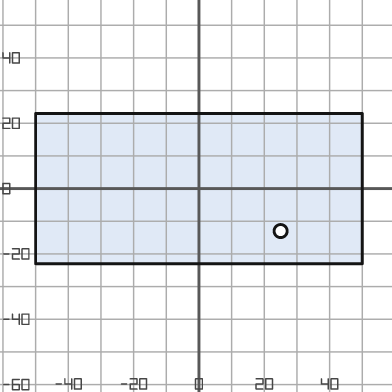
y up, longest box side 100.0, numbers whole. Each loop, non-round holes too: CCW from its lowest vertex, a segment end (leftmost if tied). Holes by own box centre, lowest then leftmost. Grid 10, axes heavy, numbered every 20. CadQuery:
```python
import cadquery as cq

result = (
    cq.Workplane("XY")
    .moveTo(-50.0, -23.0)
    .lineTo(50.0, -23.0)
    .lineTo(50.0, 23.0)
    .lineTo(-50.0, 23.0)
    .close()
    .moveTo(25.0, -13.0)
    .circle(2.0)
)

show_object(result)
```